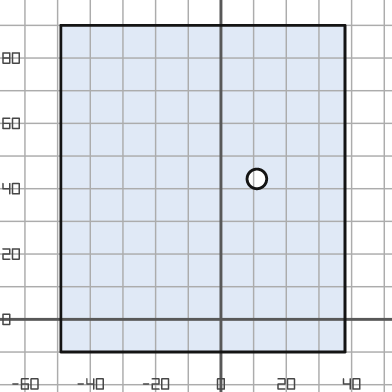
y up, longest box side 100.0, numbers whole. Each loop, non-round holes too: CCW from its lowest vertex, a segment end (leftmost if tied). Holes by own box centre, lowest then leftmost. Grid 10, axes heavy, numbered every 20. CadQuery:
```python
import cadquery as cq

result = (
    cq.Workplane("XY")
    .moveTo(-49.0, -10.0)
    .lineTo(38.0, -10.0)
    .lineTo(38.0, 90.0)
    .lineTo(-49.0, 90.0)
    .close()
    .moveTo(11.0, 43.0)
    .circle(3.0)
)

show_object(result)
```